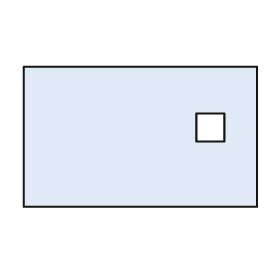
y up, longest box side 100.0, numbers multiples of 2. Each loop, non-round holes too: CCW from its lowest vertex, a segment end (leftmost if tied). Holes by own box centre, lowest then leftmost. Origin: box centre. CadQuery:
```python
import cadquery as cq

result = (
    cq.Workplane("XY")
    .moveTo(-50.0, -30.0)
    .lineTo(50.0, -30.0)
    .lineTo(50.0, 30.0)
    .lineTo(-50.0, 30.0)
    .close()
    .moveTo(24.0, -2.0)
    .lineTo(36.0, -2.0)
    .lineTo(36.0, 10.0)
    .lineTo(24.0, 10.0)
    .close()
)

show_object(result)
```